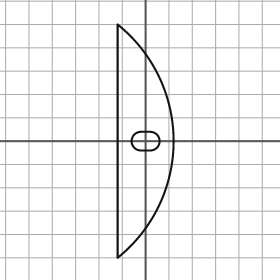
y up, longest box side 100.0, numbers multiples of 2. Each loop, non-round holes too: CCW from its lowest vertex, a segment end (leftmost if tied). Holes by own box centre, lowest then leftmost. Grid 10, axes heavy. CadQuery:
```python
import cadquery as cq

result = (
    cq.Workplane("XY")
    .moveTo(-12.0, -50.0)
    .threePointArc((12.0, 0.0), (-12.0, 50.0))
    .close()
    .moveTo(-2.0, -4.0)
    .lineTo(2.0, -4.0)
    .threePointArc((6.0, 0.0), (2.0, 4.0))
    .lineTo(-2.0, 4.0)
    .threePointArc((-6.0, 0.0), (-2.0, -4.0))
    .close()
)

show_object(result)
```